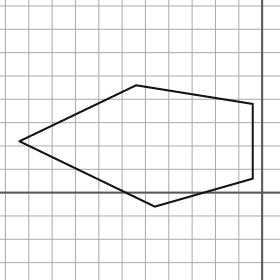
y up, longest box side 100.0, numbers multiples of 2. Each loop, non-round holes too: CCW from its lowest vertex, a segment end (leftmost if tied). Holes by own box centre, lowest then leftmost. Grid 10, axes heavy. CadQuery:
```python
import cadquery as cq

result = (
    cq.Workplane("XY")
    .moveTo(-46.0, -6.0)
    .lineTo(-4.0, 6.0)
    .lineTo(-4.0, 38.0)
    .lineTo(-54.0, 46.0)
    .lineTo(-104.0, 22.0)
    .close()
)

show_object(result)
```